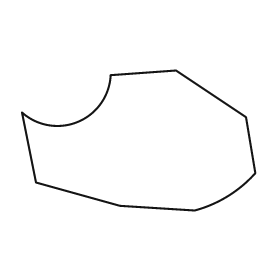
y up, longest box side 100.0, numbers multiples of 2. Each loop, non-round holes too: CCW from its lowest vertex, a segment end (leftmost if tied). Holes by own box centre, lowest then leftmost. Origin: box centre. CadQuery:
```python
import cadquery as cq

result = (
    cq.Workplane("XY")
    .moveTo(24.0, -30.0)
    .threePointArc((38.0, -24.0), (50.0, -14.0))
    .lineTo(46.0, 10.0)
    .lineTo(16.0, 30.0)
    .lineTo(-12.0, 28.0)
    .threePointArc((-26.0, 8.0), (-50.0, 12.0))
    .lineTo(-44.0, -18.0)
    .lineTo(-8.0, -28.0)
    .close()
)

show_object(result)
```